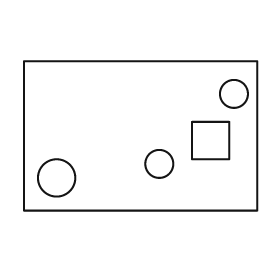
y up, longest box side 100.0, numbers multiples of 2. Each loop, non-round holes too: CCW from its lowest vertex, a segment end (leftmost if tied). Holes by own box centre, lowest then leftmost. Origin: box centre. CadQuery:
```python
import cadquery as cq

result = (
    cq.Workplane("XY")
    .moveTo(-50.0, -32.0)
    .lineTo(50.0, -32.0)
    .lineTo(50.0, 32.0)
    .lineTo(-50.0, 32.0)
    .close()
    .moveTo(-36.0, -18.0)
    .circle(8.0)
    .moveTo(8.0, -12.0)
    .circle(6.0)
    .moveTo(22.0, -10.0)
    .lineTo(38.0, -10.0)
    .lineTo(38.0, 6.0)
    .lineTo(22.0, 6.0)
    .close()
    .moveTo(40.0, 18.0)
    .circle(6.0)
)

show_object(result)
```